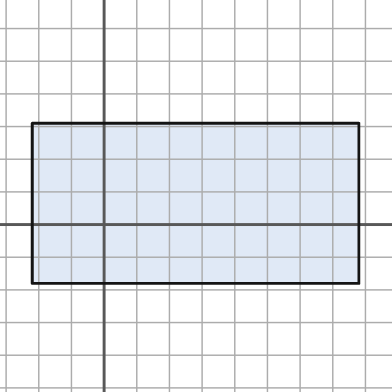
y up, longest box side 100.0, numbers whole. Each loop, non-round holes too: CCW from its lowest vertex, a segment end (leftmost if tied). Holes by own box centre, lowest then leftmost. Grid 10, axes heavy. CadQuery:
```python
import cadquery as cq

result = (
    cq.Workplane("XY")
    .moveTo(-22.0, -18.0)
    .lineTo(78.0, -18.0)
    .lineTo(78.0, 31.0)
    .lineTo(-22.0, 31.0)
    .close()
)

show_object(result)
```